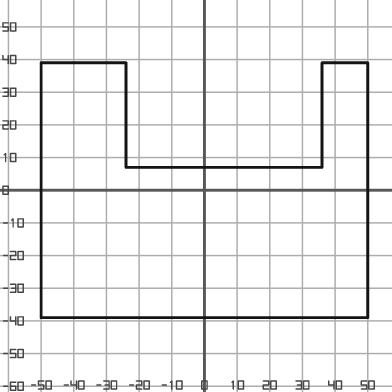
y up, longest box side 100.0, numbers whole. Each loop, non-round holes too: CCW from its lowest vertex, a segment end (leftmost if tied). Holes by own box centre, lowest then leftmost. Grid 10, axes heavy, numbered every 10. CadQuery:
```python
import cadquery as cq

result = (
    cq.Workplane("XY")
    .moveTo(-50.0, -39.0)
    .lineTo(50.0, -39.0)
    .lineTo(50.0, 39.0)
    .lineTo(36.0, 39.0)
    .lineTo(36.0, 7.0)
    .lineTo(-24.0, 7.0)
    .lineTo(-24.0, 39.0)
    .lineTo(-50.0, 39.0)
    .close()
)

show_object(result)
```